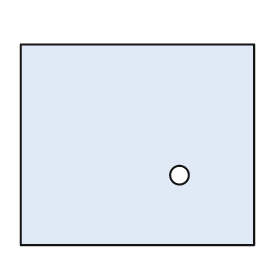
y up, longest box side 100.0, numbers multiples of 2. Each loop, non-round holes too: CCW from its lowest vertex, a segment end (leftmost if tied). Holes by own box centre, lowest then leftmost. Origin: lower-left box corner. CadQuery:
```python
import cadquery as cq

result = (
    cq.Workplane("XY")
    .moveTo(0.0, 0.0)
    .lineTo(100.0, 0.0)
    .lineTo(100.0, 86.0)
    .lineTo(0.0, 86.0)
    .close()
    .moveTo(68.0, 30.0)
    .circle(4.0)
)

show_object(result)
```